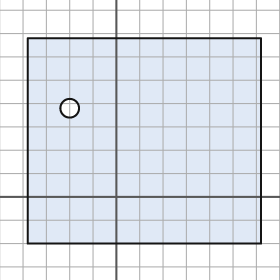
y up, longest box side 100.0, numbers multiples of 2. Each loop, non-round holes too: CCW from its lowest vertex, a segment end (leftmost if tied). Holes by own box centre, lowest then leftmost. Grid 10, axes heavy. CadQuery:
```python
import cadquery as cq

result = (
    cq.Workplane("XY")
    .moveTo(-38.0, -20.0)
    .lineTo(62.0, -20.0)
    .lineTo(62.0, 68.0)
    .lineTo(-38.0, 68.0)
    .close()
    .moveTo(-20.0, 38.0)
    .circle(4.0)
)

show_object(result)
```